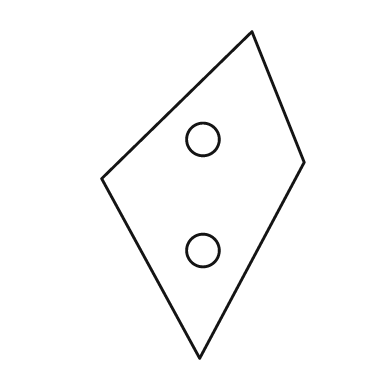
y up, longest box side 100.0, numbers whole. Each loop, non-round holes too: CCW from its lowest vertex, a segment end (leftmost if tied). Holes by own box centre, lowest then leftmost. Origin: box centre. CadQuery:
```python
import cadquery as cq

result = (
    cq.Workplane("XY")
    .moveTo(-1.0, -50.0)
    .lineTo(31.0, 10.0)
    .lineTo(15.0, 50.0)
    .lineTo(-31.0, 5.0)
    .close()
    .moveTo(0.0, -17.0)
    .circle(5.0)
    .moveTo(0.0, 17.0)
    .circle(5.0)
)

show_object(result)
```